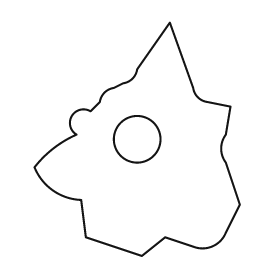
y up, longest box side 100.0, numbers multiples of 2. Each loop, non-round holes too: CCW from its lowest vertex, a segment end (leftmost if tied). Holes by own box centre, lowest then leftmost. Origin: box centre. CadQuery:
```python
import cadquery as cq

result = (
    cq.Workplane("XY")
    .moveTo(2.0, -50.0)
    .lineTo(12.0, -42.0)
    .lineTo(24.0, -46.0)
    .threePointArc((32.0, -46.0), (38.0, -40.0))
    .lineTo(44.0, -28.0)
    .lineTo(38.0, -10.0)
    .threePointArc((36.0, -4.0), (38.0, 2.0))
    .lineTo(40.0, 14.0)
    .lineTo(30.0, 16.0)
    .threePointArc((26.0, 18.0), (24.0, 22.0))
    .lineTo(14.0, 50.0)
    .lineTo(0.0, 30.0)
    .threePointArc((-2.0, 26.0), (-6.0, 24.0))
    .lineTo(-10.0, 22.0)
    .threePointArc((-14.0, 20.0), (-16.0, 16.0))
    .lineTo(-20.0, 12.0)
    .threePointArc((-28.0, 10.0), (-26.0, 2.0))
    .threePointArc((-36.0, -4.0), (-44.0, -12.0))
    .threePointArc((-36.0, -22.0), (-24.0, -26.0))
    .lineTo(-22.0, -42.0)
    .close()
    .moveTo(0.0, 0.0)
    .circle(10.0)
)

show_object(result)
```